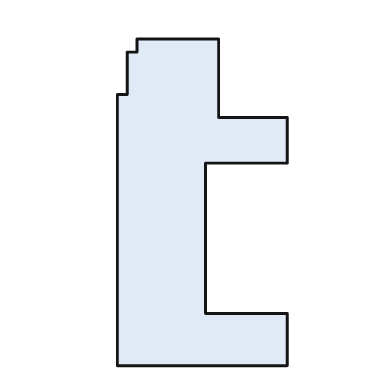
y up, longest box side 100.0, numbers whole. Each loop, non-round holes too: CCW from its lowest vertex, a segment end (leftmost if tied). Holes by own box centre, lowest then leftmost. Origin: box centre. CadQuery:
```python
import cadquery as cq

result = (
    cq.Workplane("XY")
    .moveTo(-26.0, -50.0)
    .lineTo(26.0, -50.0)
    .lineTo(26.0, -34.0)
    .lineTo(1.0, -34.0)
    .lineTo(1.0, 12.0)
    .lineTo(26.0, 12.0)
    .lineTo(26.0, 26.0)
    .lineTo(5.0, 26.0)
    .lineTo(5.0, 50.0)
    .lineTo(-20.0, 50.0)
    .lineTo(-20.0, 46.0)
    .lineTo(-23.0, 46.0)
    .lineTo(-23.0, 33.0)
    .lineTo(-26.0, 33.0)
    .close()
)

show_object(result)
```